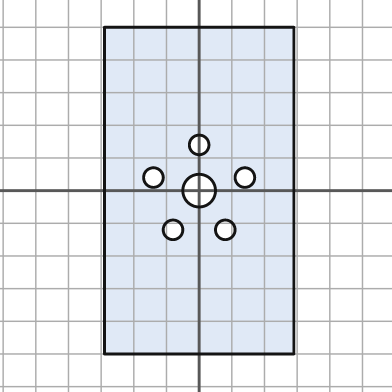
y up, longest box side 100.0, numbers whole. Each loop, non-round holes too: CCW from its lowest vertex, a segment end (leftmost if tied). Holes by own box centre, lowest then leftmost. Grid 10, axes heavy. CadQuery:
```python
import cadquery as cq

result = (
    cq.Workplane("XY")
    .moveTo(-29.0, -50.0)
    .lineTo(29.0, -50.0)
    .lineTo(29.0, 50.0)
    .lineTo(-29.0, 50.0)
    .close()
    .moveTo(-8.0, -12.0)
    .circle(3.0)
    .moveTo(8.0, -12.0)
    .circle(3.0)
    .moveTo(0.0, 0.0)
    .circle(5.0)
    .moveTo(-14.0, 4.0)
    .circle(3.0)
    .moveTo(14.0, 4.0)
    .circle(3.0)
    .moveTo(0.0, 14.0)
    .circle(3.0)
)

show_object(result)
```